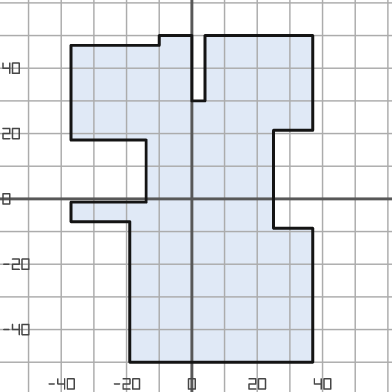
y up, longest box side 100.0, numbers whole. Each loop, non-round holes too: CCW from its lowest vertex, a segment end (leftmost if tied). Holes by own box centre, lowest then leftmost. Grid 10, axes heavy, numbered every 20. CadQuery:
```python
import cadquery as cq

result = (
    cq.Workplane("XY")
    .moveTo(-19.0, -50.0)
    .lineTo(37.0, -50.0)
    .lineTo(37.0, -9.0)
    .lineTo(25.0, -9.0)
    .lineTo(25.0, 21.0)
    .lineTo(37.0, 21.0)
    .lineTo(37.0, 50.0)
    .lineTo(4.0, 50.0)
    .lineTo(4.0, 30.0)
    .lineTo(0.0, 30.0)
    .lineTo(0.0, 50.0)
    .lineTo(-10.0, 50.0)
    .lineTo(-10.0, 47.0)
    .lineTo(-37.0, 47.0)
    .lineTo(-37.0, 18.0)
    .lineTo(-14.0, 18.0)
    .lineTo(-14.0, -1.0)
    .lineTo(-37.0, -1.0)
    .lineTo(-37.0, -7.0)
    .lineTo(-19.0, -7.0)
    .close()
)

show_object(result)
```